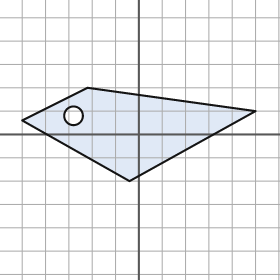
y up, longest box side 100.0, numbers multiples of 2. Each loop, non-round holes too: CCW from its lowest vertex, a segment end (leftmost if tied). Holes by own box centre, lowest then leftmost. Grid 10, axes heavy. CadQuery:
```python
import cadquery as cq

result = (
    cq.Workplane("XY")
    .moveTo(-4.0, -20.0)
    .lineTo(50.0, 10.0)
    .lineTo(-22.0, 20.0)
    .lineTo(-50.0, 6.0)
    .close()
    .moveTo(-28.0, 8.0)
    .circle(4.0)
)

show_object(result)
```